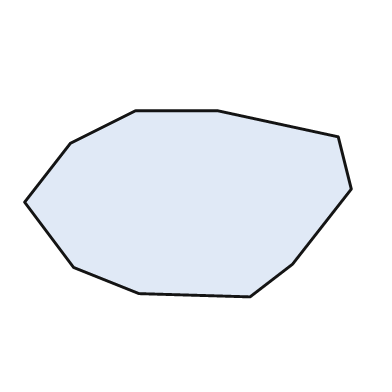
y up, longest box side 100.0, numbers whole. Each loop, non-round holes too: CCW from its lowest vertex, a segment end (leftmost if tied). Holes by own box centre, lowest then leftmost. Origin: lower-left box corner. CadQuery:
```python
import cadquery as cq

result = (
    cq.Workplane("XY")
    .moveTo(69.0, 0.0)
    .lineTo(82.0, 10.0)
    .lineTo(100.0, 33.0)
    .lineTo(96.0, 49.0)
    .lineTo(59.0, 57.0)
    .lineTo(34.0, 57.0)
    .lineTo(14.0, 47.0)
    .lineTo(0.0, 29.0)
    .lineTo(15.0, 9.0)
    .lineTo(35.0, 1.0)
    .close()
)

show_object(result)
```